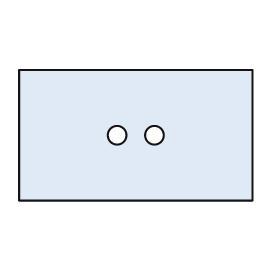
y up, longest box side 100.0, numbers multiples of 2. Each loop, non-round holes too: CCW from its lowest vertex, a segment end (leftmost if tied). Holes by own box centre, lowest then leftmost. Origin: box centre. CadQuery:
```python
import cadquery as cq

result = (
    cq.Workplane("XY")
    .moveTo(-50.0, -28.0)
    .lineTo(50.0, -28.0)
    .lineTo(50.0, 28.0)
    .lineTo(-50.0, 28.0)
    .close()
    .moveTo(-8.0, 0.0)
    .circle(4.0)
    .moveTo(8.0, 0.0)
    .circle(4.0)
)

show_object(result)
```